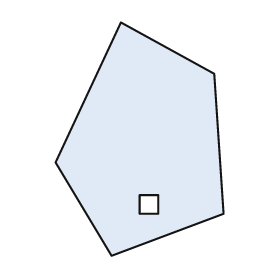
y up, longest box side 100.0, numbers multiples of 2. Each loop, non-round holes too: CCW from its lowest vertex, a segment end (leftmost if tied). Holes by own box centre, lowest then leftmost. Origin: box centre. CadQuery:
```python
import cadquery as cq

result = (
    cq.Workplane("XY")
    .moveTo(-12.0, -50.0)
    .lineTo(36.0, -32.0)
    .lineTo(32.0, 28.0)
    .lineTo(-8.0, 50.0)
    .lineTo(-36.0, -10.0)
    .close()
    .moveTo(0.0, -32.0)
    .lineTo(8.0, -32.0)
    .lineTo(8.0, -24.0)
    .lineTo(0.0, -24.0)
    .close()
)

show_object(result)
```